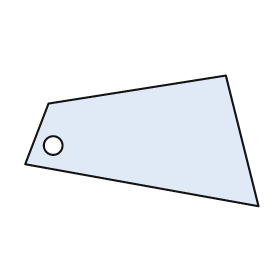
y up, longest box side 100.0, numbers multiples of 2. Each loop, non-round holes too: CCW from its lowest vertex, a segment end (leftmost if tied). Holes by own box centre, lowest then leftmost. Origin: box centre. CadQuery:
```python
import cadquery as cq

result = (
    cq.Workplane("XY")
    .moveTo(50.0, -28.0)
    .lineTo(36.0, 28.0)
    .lineTo(-40.0, 16.0)
    .lineTo(-50.0, -10.0)
    .close()
    .moveTo(-38.0, -2.0)
    .circle(4.0)
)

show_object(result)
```